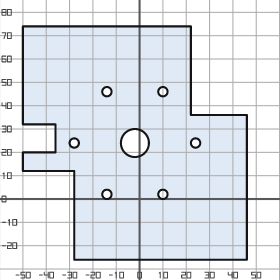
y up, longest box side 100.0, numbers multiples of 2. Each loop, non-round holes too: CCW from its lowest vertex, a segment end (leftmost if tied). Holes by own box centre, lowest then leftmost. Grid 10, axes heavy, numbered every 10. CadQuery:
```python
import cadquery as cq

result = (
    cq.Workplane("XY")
    .moveTo(-28.0, -26.0)
    .lineTo(46.0, -26.0)
    .lineTo(46.0, 36.0)
    .lineTo(22.0, 36.0)
    .lineTo(22.0, 74.0)
    .lineTo(-50.0, 74.0)
    .lineTo(-50.0, 32.0)
    .lineTo(-36.0, 32.0)
    .lineTo(-36.0, 20.0)
    .lineTo(-50.0, 20.0)
    .lineTo(-50.0, 12.0)
    .lineTo(-28.0, 12.0)
    .close()
    .moveTo(-14.0, 2.0)
    .circle(2.0)
    .moveTo(10.0, 2.0)
    .circle(2.0)
    .moveTo(-28.0, 24.0)
    .circle(2.0)
    .moveTo(-2.0, 24.0)
    .circle(6.0)
    .moveTo(24.0, 24.0)
    .circle(2.0)
    .moveTo(-14.0, 46.0)
    .circle(2.0)
    .moveTo(10.0, 46.0)
    .circle(2.0)
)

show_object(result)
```